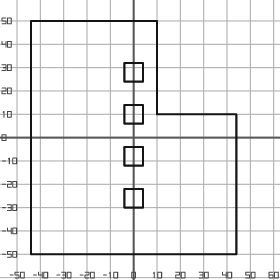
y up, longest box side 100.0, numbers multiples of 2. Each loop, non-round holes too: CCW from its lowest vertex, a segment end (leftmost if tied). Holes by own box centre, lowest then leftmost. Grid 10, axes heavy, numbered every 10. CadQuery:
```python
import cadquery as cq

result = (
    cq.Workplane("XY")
    .moveTo(-44.0, -50.0)
    .lineTo(44.0, -50.0)
    .lineTo(44.0, 10.0)
    .lineTo(10.0, 10.0)
    .lineTo(10.0, 50.0)
    .lineTo(-44.0, 50.0)
    .close()
    .moveTo(-4.0, -30.0)
    .lineTo(4.0, -30.0)
    .lineTo(4.0, -22.0)
    .lineTo(-4.0, -22.0)
    .close()
    .moveTo(-4.0, -12.0)
    .lineTo(4.0, -12.0)
    .lineTo(4.0, -4.0)
    .lineTo(-4.0, -4.0)
    .close()
    .moveTo(-4.0, 6.0)
    .lineTo(4.0, 6.0)
    .lineTo(4.0, 14.0)
    .lineTo(-4.0, 14.0)
    .close()
    .moveTo(-4.0, 24.0)
    .lineTo(4.0, 24.0)
    .lineTo(4.0, 32.0)
    .lineTo(-4.0, 32.0)
    .close()
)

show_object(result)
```